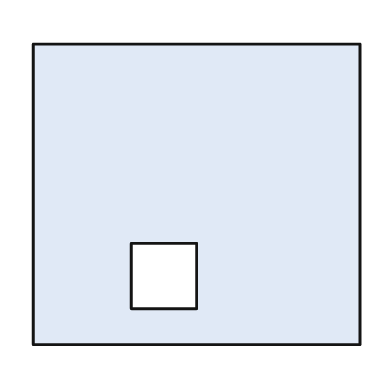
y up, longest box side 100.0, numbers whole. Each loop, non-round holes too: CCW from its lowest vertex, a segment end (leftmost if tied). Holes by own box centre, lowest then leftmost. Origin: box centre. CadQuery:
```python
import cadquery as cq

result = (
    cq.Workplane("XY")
    .moveTo(-50.0, -46.0)
    .lineTo(50.0, -46.0)
    .lineTo(50.0, 46.0)
    .lineTo(-50.0, 46.0)
    .close()
    .moveTo(-20.0, -35.0)
    .lineTo(0.0, -35.0)
    .lineTo(0.0, -15.0)
    .lineTo(-20.0, -15.0)
    .close()
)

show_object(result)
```